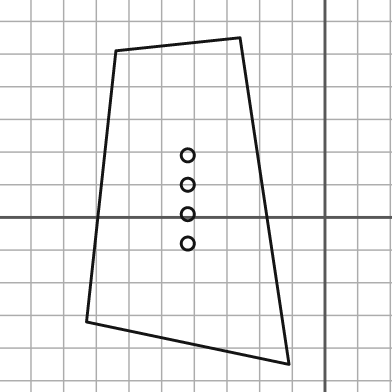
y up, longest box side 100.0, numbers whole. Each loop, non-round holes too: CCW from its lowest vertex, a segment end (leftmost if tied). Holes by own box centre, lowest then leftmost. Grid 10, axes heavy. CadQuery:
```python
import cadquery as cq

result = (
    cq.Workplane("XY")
    .moveTo(-11.0, -45.0)
    .lineTo(-26.0, 55.0)
    .lineTo(-64.0, 51.0)
    .lineTo(-73.0, -32.0)
    .close()
    .moveTo(-42.0, -8.0)
    .circle(2.0)
    .moveTo(-42.0, 1.0)
    .circle(2.0)
    .moveTo(-42.0, 10.0)
    .circle(2.0)
    .moveTo(-42.0, 19.0)
    .circle(2.0)
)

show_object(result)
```